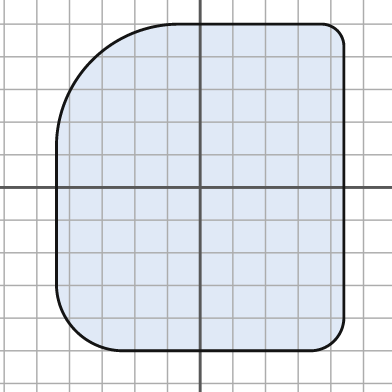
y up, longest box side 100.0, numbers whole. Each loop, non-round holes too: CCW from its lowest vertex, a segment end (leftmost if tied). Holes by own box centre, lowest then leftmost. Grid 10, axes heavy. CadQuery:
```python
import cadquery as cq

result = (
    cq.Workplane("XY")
    .moveTo(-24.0, -50.0)
    .lineTo(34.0, -50.0)
    .threePointArc((41.0, -47.0), (44.0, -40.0))
    .lineTo(44.0, 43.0)
    .threePointArc((42.0, 48.0), (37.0, 50.0))
    .lineTo(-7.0, 50.0)
    .threePointArc((-33.0, 39.0), (-44.0, 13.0))
    .lineTo(-44.0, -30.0)
    .threePointArc((-38.0, -44.0), (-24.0, -50.0))
    .close()
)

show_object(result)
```